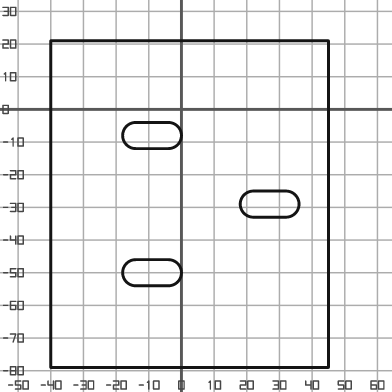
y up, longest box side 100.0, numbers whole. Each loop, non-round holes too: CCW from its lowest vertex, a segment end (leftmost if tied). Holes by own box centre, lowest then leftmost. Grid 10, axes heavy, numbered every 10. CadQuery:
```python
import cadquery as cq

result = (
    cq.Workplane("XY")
    .moveTo(-40.0, -79.0)
    .lineTo(45.0, -79.0)
    .lineTo(45.0, 21.0)
    .lineTo(-40.0, 21.0)
    .close()
    .moveTo(-14.0, -54.0)
    .lineTo(-4.0, -54.0)
    .threePointArc((0.0, -50.0), (-4.0, -46.0))
    .lineTo(-14.0, -46.0)
    .threePointArc((-18.0, -50.0), (-14.0, -54.0))
    .close()
    .moveTo(22.0, -33.0)
    .lineTo(32.0, -33.0)
    .threePointArc((36.0, -29.0), (32.0, -25.0))
    .lineTo(22.0, -25.0)
    .threePointArc((18.0, -29.0), (22.0, -33.0))
    .close()
    .moveTo(-14.0, -12.0)
    .lineTo(-4.0, -12.0)
    .threePointArc((0.0, -8.0), (-4.0, -4.0))
    .lineTo(-14.0, -4.0)
    .threePointArc((-18.0, -8.0), (-14.0, -12.0))
    .close()
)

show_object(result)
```